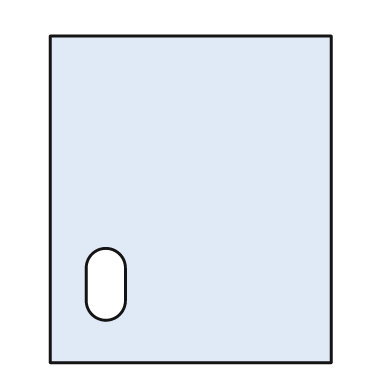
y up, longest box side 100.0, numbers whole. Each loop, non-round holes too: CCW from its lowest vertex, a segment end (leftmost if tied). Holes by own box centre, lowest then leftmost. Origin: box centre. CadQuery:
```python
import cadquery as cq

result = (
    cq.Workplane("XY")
    .moveTo(-43.0, -50.0)
    .lineTo(43.0, -50.0)
    .lineTo(43.0, 50.0)
    .lineTo(-43.0, 50.0)
    .close()
    .moveTo(-32.0, -31.0)
    .threePointArc((-26.0, -37.0), (-20.0, -31.0))
    .lineTo(-20.0, -21.0)
    .threePointArc((-26.0, -15.0), (-32.0, -21.0))
    .close()
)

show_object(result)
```